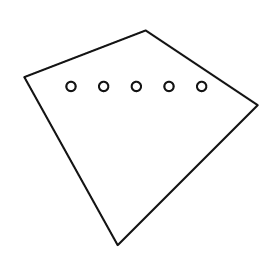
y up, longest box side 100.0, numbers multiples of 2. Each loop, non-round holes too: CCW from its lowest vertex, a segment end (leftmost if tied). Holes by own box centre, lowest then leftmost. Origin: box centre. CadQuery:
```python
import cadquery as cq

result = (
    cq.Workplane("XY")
    .moveTo(-10.0, -46.0)
    .lineTo(50.0, 14.0)
    .lineTo(2.0, 46.0)
    .lineTo(-50.0, 26.0)
    .close()
    .moveTo(-30.0, 22.0)
    .circle(2.0)
    .moveTo(-16.0, 22.0)
    .circle(2.0)
    .moveTo(-2.0, 22.0)
    .circle(2.0)
    .moveTo(12.0, 22.0)
    .circle(2.0)
    .moveTo(26.0, 22.0)
    .circle(2.0)
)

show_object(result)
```